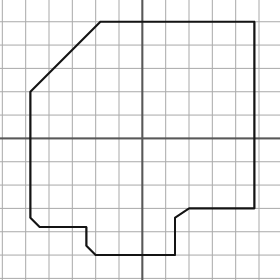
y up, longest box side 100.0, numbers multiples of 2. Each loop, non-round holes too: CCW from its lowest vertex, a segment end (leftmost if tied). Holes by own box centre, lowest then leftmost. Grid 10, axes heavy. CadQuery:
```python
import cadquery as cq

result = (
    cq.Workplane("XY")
    .moveTo(-20.0, -50.0)
    .lineTo(14.0, -50.0)
    .lineTo(14.0, -34.0)
    .lineTo(20.0, -30.0)
    .lineTo(48.0, -30.0)
    .lineTo(48.0, 50.0)
    .lineTo(-18.0, 50.0)
    .lineTo(-48.0, 20.0)
    .lineTo(-48.0, -34.0)
    .lineTo(-44.0, -38.0)
    .lineTo(-24.0, -38.0)
    .lineTo(-24.0, -46.0)
    .close()
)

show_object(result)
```